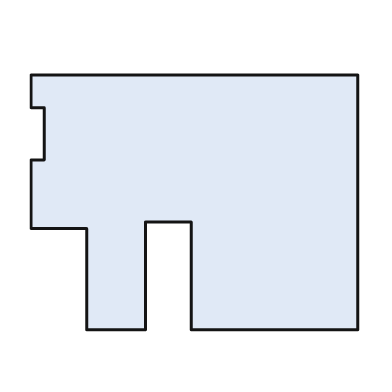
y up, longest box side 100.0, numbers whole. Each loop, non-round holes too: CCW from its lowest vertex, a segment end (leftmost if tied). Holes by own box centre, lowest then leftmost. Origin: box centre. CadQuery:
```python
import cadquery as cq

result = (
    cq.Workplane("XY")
    .moveTo(-33.0, -39.0)
    .lineTo(-15.0, -39.0)
    .lineTo(-15.0, -6.0)
    .lineTo(-1.0, -6.0)
    .lineTo(-1.0, -39.0)
    .lineTo(50.0, -39.0)
    .lineTo(50.0, 39.0)
    .lineTo(-50.0, 39.0)
    .lineTo(-50.0, 29.0)
    .lineTo(-46.0, 29.0)
    .lineTo(-46.0, 13.0)
    .lineTo(-50.0, 13.0)
    .lineTo(-50.0, -8.0)
    .lineTo(-33.0, -8.0)
    .close()
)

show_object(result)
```